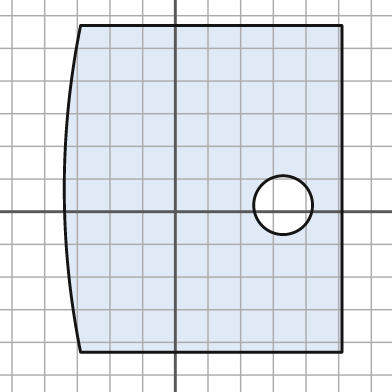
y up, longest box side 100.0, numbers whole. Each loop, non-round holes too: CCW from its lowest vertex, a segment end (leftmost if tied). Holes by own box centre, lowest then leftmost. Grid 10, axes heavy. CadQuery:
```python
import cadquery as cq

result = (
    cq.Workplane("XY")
    .moveTo(-29.0, -43.0)
    .lineTo(51.0, -43.0)
    .lineTo(51.0, 57.0)
    .lineTo(-29.0, 57.0)
    .threePointArc((-34.0, 7.0), (-29.0, -43.0))
    .close()
    .moveTo(33.0, 2.0)
    .circle(9.0)
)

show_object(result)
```